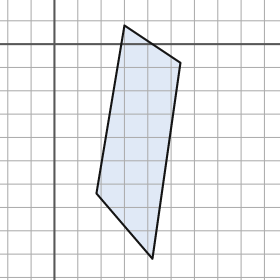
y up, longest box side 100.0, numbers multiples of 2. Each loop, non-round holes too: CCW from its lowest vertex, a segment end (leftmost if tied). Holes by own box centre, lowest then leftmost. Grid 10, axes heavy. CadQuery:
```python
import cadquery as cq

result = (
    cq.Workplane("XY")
    .moveTo(42.0, -92.0)
    .lineTo(54.0, -8.0)
    .lineTo(30.0, 8.0)
    .lineTo(18.0, -64.0)
    .close()
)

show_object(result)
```